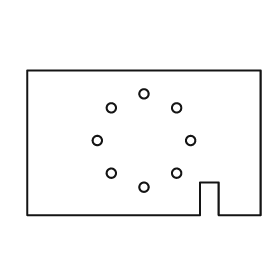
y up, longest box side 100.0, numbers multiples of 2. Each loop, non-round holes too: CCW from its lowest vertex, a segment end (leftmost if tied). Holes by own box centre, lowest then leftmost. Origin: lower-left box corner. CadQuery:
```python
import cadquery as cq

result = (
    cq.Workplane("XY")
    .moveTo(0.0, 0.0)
    .lineTo(74.0, 0.0)
    .lineTo(74.0, 14.0)
    .lineTo(82.0, 14.0)
    .lineTo(82.0, 0.0)
    .lineTo(100.0, 0.0)
    .lineTo(100.0, 62.0)
    .lineTo(0.0, 62.0)
    .close()
    .moveTo(50.0, 12.0)
    .circle(2.0)
    .moveTo(36.0, 18.0)
    .circle(2.0)
    .moveTo(64.0, 18.0)
    .circle(2.0)
    .moveTo(30.0, 32.0)
    .circle(2.0)
    .moveTo(70.0, 32.0)
    .circle(2.0)
    .moveTo(36.0, 46.0)
    .circle(2.0)
    .moveTo(64.0, 46.0)
    .circle(2.0)
    .moveTo(50.0, 52.0)
    .circle(2.0)
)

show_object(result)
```